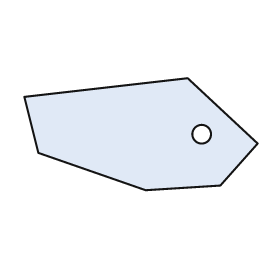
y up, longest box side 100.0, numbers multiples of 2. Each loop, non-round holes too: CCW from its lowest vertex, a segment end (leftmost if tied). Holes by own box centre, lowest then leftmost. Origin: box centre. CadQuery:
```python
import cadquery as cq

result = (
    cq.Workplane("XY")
    .moveTo(2.0, -24.0)
    .lineTo(34.0, -22.0)
    .lineTo(50.0, -4.0)
    .lineTo(20.0, 24.0)
    .lineTo(-50.0, 16.0)
    .lineTo(-44.0, -8.0)
    .close()
    .moveTo(26.0, 0.0)
    .circle(4.0)
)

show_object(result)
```